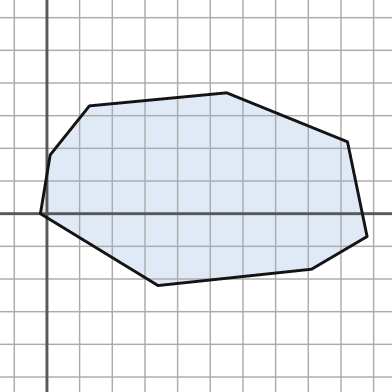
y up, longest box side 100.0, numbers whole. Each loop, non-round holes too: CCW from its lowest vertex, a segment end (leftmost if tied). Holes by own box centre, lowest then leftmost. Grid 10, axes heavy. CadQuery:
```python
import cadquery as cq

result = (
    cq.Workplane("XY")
    .moveTo(34.0, -22.0)
    .lineTo(81.0, -17.0)
    .lineTo(98.0, -7.0)
    .lineTo(92.0, 22.0)
    .lineTo(55.0, 37.0)
    .lineTo(13.0, 33.0)
    .lineTo(1.0, 18.0)
    .lineTo(-2.0, 0.0)
    .close()
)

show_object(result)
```